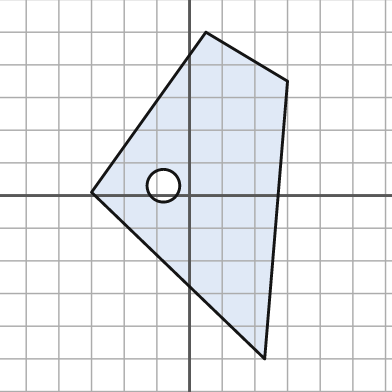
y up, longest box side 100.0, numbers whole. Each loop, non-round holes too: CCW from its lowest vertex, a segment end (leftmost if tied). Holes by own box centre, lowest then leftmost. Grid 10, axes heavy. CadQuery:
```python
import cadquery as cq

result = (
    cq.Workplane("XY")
    .moveTo(23.0, -50.0)
    .lineTo(30.0, 35.0)
    .lineTo(5.0, 50.0)
    .lineTo(-30.0, 1.0)
    .close()
    .moveTo(-8.0, 3.0)
    .circle(5.0)
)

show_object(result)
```